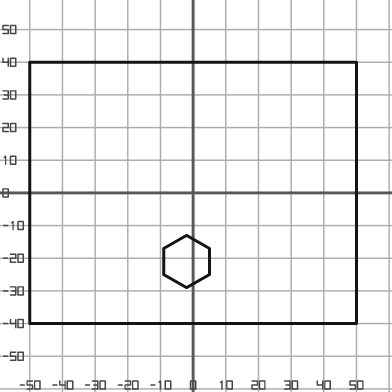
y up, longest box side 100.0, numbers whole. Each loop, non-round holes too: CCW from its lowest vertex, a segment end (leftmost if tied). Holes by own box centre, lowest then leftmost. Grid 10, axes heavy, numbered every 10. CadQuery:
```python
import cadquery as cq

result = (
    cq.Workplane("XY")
    .moveTo(-50.0, -40.0)
    .lineTo(50.0, -40.0)
    .lineTo(50.0, 40.0)
    .lineTo(-50.0, 40.0)
    .close()
    .moveTo(-2.0, -29.0)
    .lineTo(5.0, -25.0)
    .lineTo(5.0, -17.0)
    .lineTo(-2.0, -13.0)
    .lineTo(-9.0, -17.0)
    .lineTo(-9.0, -25.0)
    .close()
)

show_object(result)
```